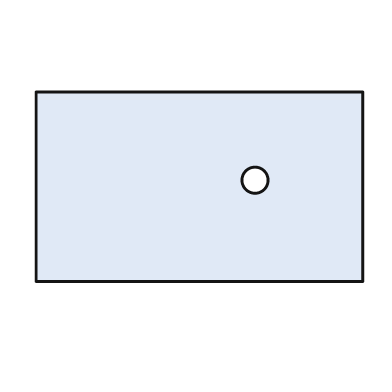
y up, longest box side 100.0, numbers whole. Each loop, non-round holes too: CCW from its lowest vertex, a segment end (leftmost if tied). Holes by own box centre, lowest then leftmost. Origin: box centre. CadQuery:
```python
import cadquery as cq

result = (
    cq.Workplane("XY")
    .moveTo(-50.0, -29.0)
    .lineTo(50.0, -29.0)
    .lineTo(50.0, 29.0)
    .lineTo(-50.0, 29.0)
    .close()
    .moveTo(17.0, 2.0)
    .circle(4.0)
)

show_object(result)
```